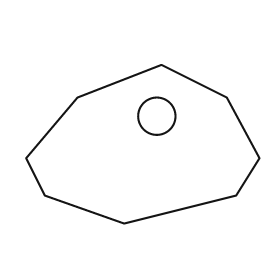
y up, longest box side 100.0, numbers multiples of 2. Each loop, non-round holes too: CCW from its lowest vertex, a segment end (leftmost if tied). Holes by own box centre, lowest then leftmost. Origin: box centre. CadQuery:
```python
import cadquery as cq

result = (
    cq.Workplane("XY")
    .moveTo(-8.0, -34.0)
    .lineTo(40.0, -22.0)
    .lineTo(50.0, -6.0)
    .lineTo(36.0, 20.0)
    .lineTo(8.0, 34.0)
    .lineTo(-28.0, 20.0)
    .lineTo(-50.0, -6.0)
    .lineTo(-42.0, -22.0)
    .close()
    .moveTo(6.0, 12.0)
    .circle(8.0)
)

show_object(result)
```